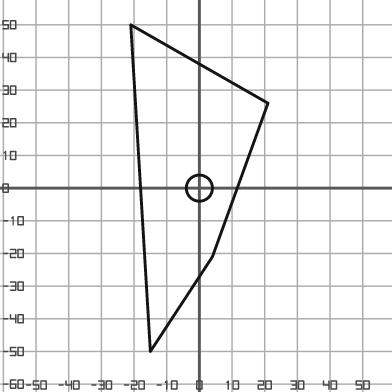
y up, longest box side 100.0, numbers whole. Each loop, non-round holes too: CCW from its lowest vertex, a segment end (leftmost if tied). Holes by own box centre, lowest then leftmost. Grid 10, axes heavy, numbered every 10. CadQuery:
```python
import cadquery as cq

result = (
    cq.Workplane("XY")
    .moveTo(-15.0, -50.0)
    .lineTo(4.0, -21.0)
    .lineTo(21.0, 26.0)
    .lineTo(-21.0, 50.0)
    .close()
    .moveTo(0.0, 0.0)
    .circle(4.0)
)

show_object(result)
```